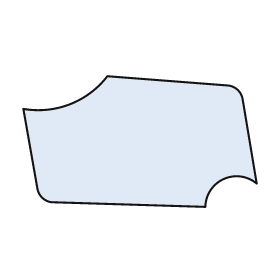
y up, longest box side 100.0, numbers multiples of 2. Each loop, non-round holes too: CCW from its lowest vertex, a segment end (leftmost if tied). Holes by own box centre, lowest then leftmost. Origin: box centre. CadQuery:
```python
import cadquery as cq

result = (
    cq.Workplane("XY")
    .moveTo(28.0, -28.0)
    .threePointArc((36.0, -16.0), (50.0, -18.0))
    .lineTo(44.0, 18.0)
    .threePointArc((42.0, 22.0), (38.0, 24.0))
    .lineTo(-14.0, 28.0)
    .threePointArc((-30.0, 16.0), (-50.0, 14.0))
    .lineTo(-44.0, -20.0)
    .threePointArc((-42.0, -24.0), (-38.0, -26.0))
    .close()
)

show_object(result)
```